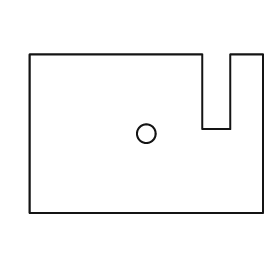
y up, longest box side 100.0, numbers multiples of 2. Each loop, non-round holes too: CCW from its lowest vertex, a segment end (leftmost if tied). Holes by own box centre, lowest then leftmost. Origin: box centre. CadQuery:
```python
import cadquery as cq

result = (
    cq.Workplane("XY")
    .moveTo(-50.0, -34.0)
    .lineTo(50.0, -34.0)
    .lineTo(50.0, 34.0)
    .lineTo(36.0, 34.0)
    .lineTo(36.0, 2.0)
    .lineTo(24.0, 2.0)
    .lineTo(24.0, 34.0)
    .lineTo(-50.0, 34.0)
    .close()
    .moveTo(0.0, 0.0)
    .circle(4.0)
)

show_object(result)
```